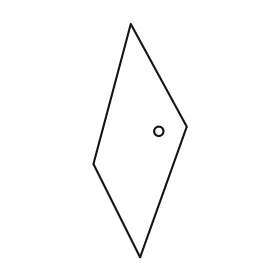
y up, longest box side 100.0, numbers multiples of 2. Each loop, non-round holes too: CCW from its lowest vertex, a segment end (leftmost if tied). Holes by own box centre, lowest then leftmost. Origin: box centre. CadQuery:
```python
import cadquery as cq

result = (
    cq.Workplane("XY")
    .moveTo(0.0, -50.0)
    .lineTo(20.0, 6.0)
    .lineTo(-4.0, 50.0)
    .lineTo(-20.0, -10.0)
    .close()
    .moveTo(8.0, 4.0)
    .circle(2.0)
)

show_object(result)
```